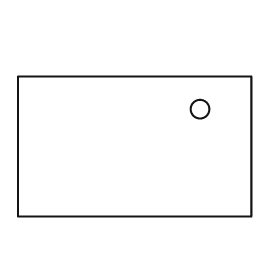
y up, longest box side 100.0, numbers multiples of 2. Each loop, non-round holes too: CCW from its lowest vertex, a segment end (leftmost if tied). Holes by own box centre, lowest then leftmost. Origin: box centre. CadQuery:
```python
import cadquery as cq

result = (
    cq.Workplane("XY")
    .moveTo(-50.0, -30.0)
    .lineTo(50.0, -30.0)
    .lineTo(50.0, 30.0)
    .lineTo(-50.0, 30.0)
    .close()
    .moveTo(28.0, 16.0)
    .circle(4.0)
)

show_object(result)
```